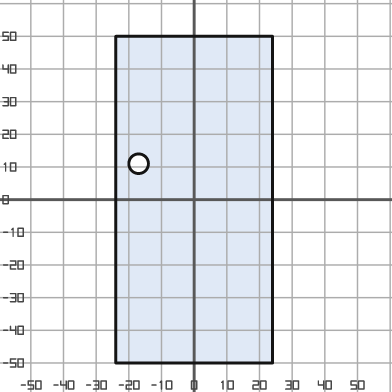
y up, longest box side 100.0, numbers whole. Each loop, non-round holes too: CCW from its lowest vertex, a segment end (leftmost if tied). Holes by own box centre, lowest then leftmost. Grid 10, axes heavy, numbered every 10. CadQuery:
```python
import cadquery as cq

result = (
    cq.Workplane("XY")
    .moveTo(-24.0, -50.0)
    .lineTo(24.0, -50.0)
    .lineTo(24.0, 50.0)
    .lineTo(-24.0, 50.0)
    .close()
    .moveTo(-17.0, 11.0)
    .circle(3.0)
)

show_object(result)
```